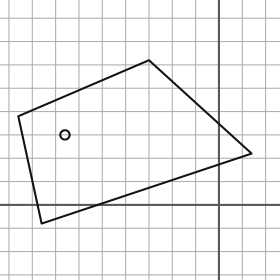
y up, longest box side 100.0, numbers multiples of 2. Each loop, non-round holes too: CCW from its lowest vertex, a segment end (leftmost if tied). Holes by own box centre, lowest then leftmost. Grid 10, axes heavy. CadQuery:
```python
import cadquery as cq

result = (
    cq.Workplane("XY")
    .moveTo(-76.0, -8.0)
    .lineTo(14.0, 22.0)
    .lineTo(-30.0, 62.0)
    .lineTo(-86.0, 38.0)
    .close()
    .moveTo(-66.0, 30.0)
    .circle(2.0)
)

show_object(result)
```